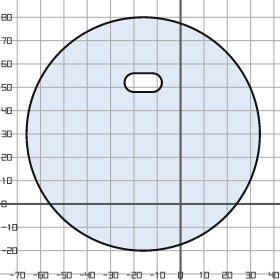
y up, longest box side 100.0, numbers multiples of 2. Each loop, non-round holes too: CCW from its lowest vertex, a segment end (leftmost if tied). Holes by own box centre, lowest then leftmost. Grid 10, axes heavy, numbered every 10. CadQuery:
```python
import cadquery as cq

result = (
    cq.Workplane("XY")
    .moveTo(-16.0, 30.0)
    .circle(50.0)
    .moveTo(-20.0, 48.0)
    .lineTo(-12.0, 48.0)
    .threePointArc((-8.0, 52.0), (-12.0, 56.0))
    .lineTo(-20.0, 56.0)
    .threePointArc((-24.0, 52.0), (-20.0, 48.0))
    .close()
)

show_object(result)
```